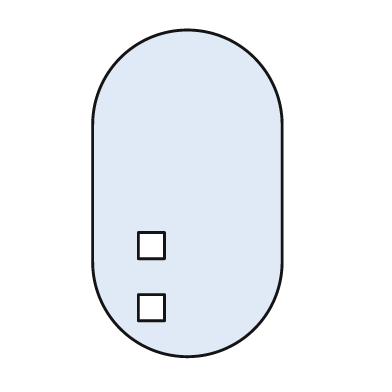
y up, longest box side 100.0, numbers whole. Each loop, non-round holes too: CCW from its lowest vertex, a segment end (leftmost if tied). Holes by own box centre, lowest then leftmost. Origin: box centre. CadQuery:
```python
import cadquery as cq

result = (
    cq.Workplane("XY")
    .moveTo(-29.0, -21.0)
    .threePointArc((0.0, -50.0), (29.0, -21.0))
    .lineTo(29.0, 21.0)
    .threePointArc((0.0, 50.0), (-29.0, 21.0))
    .close()
    .moveTo(-15.0, -39.0)
    .lineTo(-7.0, -39.0)
    .lineTo(-7.0, -31.0)
    .lineTo(-15.0, -31.0)
    .close()
    .moveTo(-15.0, -20.0)
    .lineTo(-7.0, -20.0)
    .lineTo(-7.0, -12.0)
    .lineTo(-15.0, -12.0)
    .close()
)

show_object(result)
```